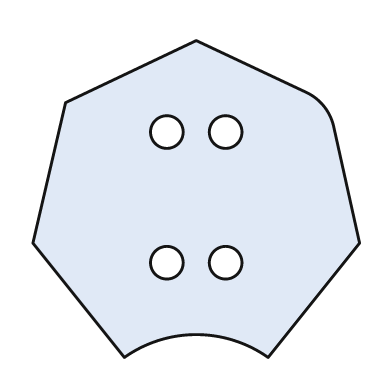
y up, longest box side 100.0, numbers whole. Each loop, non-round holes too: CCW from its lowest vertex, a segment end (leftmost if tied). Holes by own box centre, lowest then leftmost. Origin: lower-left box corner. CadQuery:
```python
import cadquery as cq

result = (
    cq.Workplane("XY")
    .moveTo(28.0, 0.0)
    .threePointArc((50.0, 7.0), (72.0, 0.0))
    .lineTo(100.0, 35.0)
    .lineTo(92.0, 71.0)
    .threePointArc((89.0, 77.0), (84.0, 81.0))
    .lineTo(50.0, 97.0)
    .lineTo(10.0, 78.0)
    .lineTo(0.0, 35.0)
    .close()
    .moveTo(41.0, 29.0)
    .circle(5.0)
    .moveTo(59.0, 29.0)
    .circle(5.0)
    .moveTo(41.0, 69.0)
    .circle(5.0)
    .moveTo(59.0, 69.0)
    .circle(5.0)
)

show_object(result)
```